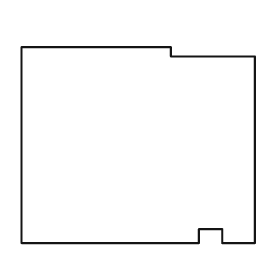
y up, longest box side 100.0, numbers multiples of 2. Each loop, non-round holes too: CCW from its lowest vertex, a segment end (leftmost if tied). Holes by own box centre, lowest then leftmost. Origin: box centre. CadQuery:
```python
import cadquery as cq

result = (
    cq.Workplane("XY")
    .moveTo(-50.0, -42.0)
    .lineTo(26.0, -42.0)
    .lineTo(26.0, -36.0)
    .lineTo(36.0, -36.0)
    .lineTo(36.0, -42.0)
    .lineTo(50.0, -42.0)
    .lineTo(50.0, 38.0)
    .lineTo(14.0, 38.0)
    .lineTo(14.0, 42.0)
    .lineTo(-50.0, 42.0)
    .close()
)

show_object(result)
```